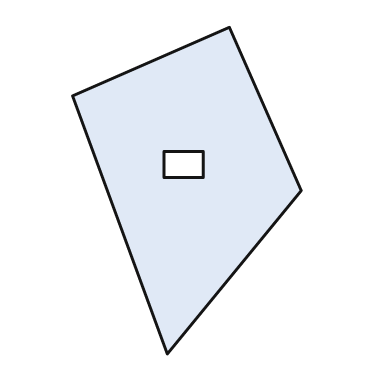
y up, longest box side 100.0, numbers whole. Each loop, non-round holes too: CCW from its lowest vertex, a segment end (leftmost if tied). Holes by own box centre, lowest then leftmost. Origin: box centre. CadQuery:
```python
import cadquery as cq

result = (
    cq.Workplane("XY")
    .moveTo(-6.0, -50.0)
    .lineTo(35.0, 0.0)
    .lineTo(13.0, 50.0)
    .lineTo(-35.0, 29.0)
    .close()
    .moveTo(-7.0, 4.0)
    .lineTo(5.0, 4.0)
    .lineTo(5.0, 12.0)
    .lineTo(-7.0, 12.0)
    .close()
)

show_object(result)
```